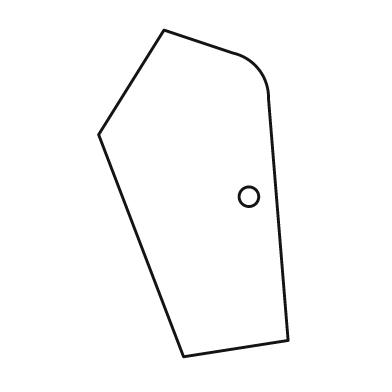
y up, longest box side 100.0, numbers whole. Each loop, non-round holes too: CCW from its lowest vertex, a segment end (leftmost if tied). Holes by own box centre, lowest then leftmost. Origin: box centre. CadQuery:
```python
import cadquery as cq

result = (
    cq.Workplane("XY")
    .moveTo(-3.0, -50.0)
    .lineTo(29.0, -45.0)
    .lineTo(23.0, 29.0)
    .threePointArc((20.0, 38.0), (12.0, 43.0))
    .lineTo(-9.0, 50.0)
    .lineTo(-29.0, 18.0)
    .close()
    .moveTo(17.0, -1.0)
    .circle(3.0)
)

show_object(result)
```